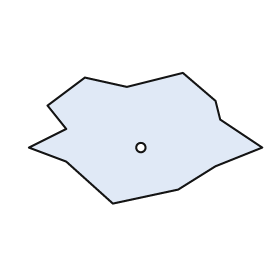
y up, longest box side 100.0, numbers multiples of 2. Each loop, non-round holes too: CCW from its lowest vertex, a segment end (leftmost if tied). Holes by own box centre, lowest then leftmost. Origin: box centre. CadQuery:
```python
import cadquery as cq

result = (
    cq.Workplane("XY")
    .moveTo(-14.0, -28.0)
    .lineTo(14.0, -22.0)
    .lineTo(30.0, -12.0)
    .lineTo(50.0, -4.0)
    .lineTo(32.0, 8.0)
    .lineTo(30.0, 16.0)
    .lineTo(16.0, 28.0)
    .lineTo(-8.0, 22.0)
    .lineTo(-26.0, 26.0)
    .lineTo(-42.0, 14.0)
    .lineTo(-34.0, 4.0)
    .lineTo(-50.0, -4.0)
    .lineTo(-34.0, -10.0)
    .close()
    .moveTo(-2.0, -4.0)
    .circle(2.0)
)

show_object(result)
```